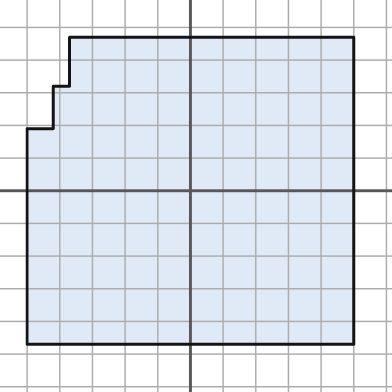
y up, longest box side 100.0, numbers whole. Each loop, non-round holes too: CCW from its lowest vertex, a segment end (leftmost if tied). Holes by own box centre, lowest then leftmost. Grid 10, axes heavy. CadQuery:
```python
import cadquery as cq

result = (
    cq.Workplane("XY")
    .moveTo(-50.0, -47.0)
    .lineTo(50.0, -47.0)
    .lineTo(50.0, 47.0)
    .lineTo(-37.0, 47.0)
    .lineTo(-37.0, 32.0)
    .lineTo(-42.0, 32.0)
    .lineTo(-42.0, 19.0)
    .lineTo(-50.0, 19.0)
    .close()
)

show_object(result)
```